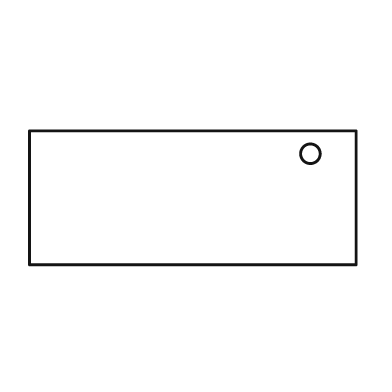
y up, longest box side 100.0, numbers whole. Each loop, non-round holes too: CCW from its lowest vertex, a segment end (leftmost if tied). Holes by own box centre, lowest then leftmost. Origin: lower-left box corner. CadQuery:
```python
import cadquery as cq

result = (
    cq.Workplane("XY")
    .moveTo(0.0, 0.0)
    .lineTo(100.0, 0.0)
    .lineTo(100.0, 41.0)
    .lineTo(0.0, 41.0)
    .close()
    .moveTo(86.0, 34.0)
    .circle(3.0)
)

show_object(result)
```